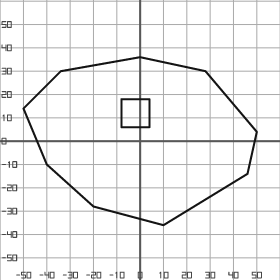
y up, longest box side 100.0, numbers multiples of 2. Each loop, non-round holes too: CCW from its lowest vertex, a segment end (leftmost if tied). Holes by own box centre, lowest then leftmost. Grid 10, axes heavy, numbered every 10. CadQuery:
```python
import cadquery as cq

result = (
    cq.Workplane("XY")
    .moveTo(10.0, -36.0)
    .lineTo(46.0, -14.0)
    .lineTo(50.0, 4.0)
    .lineTo(28.0, 30.0)
    .lineTo(0.0, 36.0)
    .lineTo(-34.0, 30.0)
    .lineTo(-50.0, 14.0)
    .lineTo(-40.0, -10.0)
    .lineTo(-20.0, -28.0)
    .close()
    .moveTo(-8.0, 6.0)
    .lineTo(4.0, 6.0)
    .lineTo(4.0, 18.0)
    .lineTo(-8.0, 18.0)
    .close()
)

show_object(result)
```